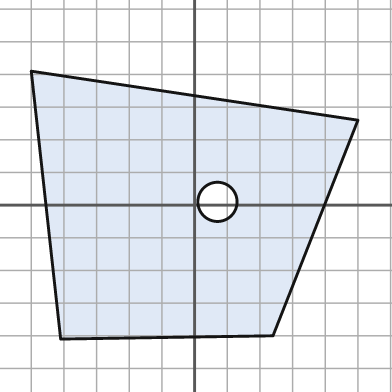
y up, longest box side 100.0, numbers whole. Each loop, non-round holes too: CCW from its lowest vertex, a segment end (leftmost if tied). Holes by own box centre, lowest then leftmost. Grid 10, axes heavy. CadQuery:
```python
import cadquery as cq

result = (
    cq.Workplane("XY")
    .moveTo(-41.0, -41.0)
    .lineTo(24.0, -40.0)
    .lineTo(50.0, 26.0)
    .lineTo(-50.0, 41.0)
    .close()
    .moveTo(7.0, 1.0)
    .circle(6.0)
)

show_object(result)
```